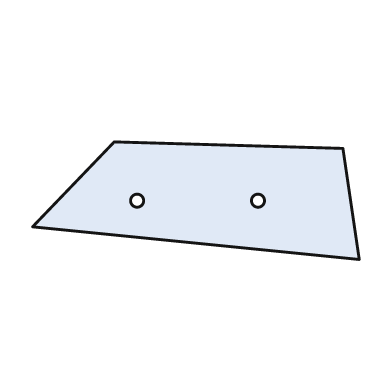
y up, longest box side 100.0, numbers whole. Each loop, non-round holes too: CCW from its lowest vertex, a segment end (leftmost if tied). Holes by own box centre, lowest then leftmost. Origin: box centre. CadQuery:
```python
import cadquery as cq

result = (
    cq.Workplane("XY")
    .moveTo(50.0, -18.0)
    .lineTo(45.0, 16.0)
    .lineTo(-25.0, 18.0)
    .lineTo(-50.0, -8.0)
    .close()
    .moveTo(-18.0, 0.0)
    .circle(2.0)
    .moveTo(19.0, 0.0)
    .circle(2.0)
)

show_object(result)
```